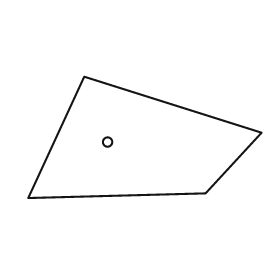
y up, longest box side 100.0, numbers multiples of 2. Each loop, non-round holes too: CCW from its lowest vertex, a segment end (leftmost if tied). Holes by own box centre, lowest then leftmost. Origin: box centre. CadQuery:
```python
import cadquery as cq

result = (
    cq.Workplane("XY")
    .moveTo(-50.0, -26.0)
    .lineTo(26.0, -24.0)
    .lineTo(50.0, 2.0)
    .lineTo(-26.0, 26.0)
    .close()
    .moveTo(-16.0, -2.0)
    .circle(2.0)
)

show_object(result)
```